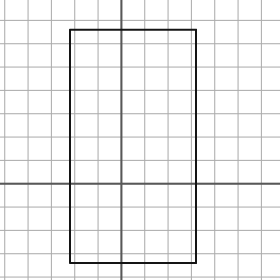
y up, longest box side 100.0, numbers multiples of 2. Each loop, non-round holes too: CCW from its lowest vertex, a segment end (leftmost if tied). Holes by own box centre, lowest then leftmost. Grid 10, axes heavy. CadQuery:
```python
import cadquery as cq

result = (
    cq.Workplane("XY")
    .moveTo(-22.0, -34.0)
    .lineTo(32.0, -34.0)
    .lineTo(32.0, 66.0)
    .lineTo(-22.0, 66.0)
    .close()
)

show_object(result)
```